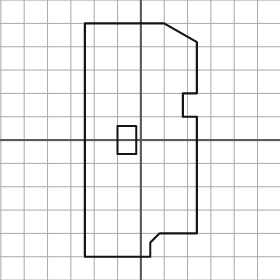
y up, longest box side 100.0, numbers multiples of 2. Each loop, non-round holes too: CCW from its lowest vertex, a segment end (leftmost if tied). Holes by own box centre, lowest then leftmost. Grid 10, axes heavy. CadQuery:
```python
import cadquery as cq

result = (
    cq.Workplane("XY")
    .moveTo(-24.0, -50.0)
    .lineTo(4.0, -50.0)
    .lineTo(4.0, -44.0)
    .lineTo(8.0, -40.0)
    .lineTo(24.0, -40.0)
    .lineTo(24.0, 10.0)
    .lineTo(18.0, 10.0)
    .lineTo(18.0, 20.0)
    .lineTo(24.0, 20.0)
    .lineTo(24.0, 42.0)
    .lineTo(10.0, 50.0)
    .lineTo(-24.0, 50.0)
    .close()
    .moveTo(-10.0, -6.0)
    .lineTo(-2.0, -6.0)
    .lineTo(-2.0, 6.0)
    .lineTo(-10.0, 6.0)
    .close()
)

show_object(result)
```